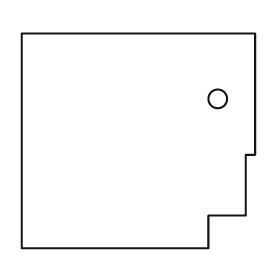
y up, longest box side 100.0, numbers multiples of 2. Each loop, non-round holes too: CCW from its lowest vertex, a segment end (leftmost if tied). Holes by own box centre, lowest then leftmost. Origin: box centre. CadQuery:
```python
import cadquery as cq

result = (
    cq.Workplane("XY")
    .moveTo(-50.0, -46.0)
    .lineTo(30.0, -46.0)
    .lineTo(30.0, -32.0)
    .lineTo(46.0, -32.0)
    .lineTo(46.0, -6.0)
    .lineTo(50.0, -6.0)
    .lineTo(50.0, 46.0)
    .lineTo(-50.0, 46.0)
    .close()
    .moveTo(34.0, 18.0)
    .circle(4.0)
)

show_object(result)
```